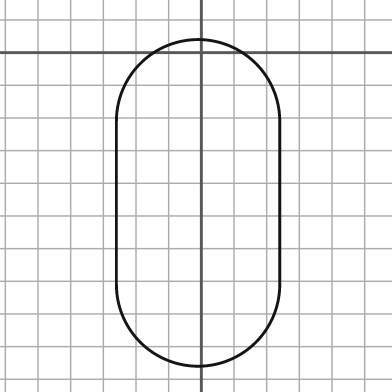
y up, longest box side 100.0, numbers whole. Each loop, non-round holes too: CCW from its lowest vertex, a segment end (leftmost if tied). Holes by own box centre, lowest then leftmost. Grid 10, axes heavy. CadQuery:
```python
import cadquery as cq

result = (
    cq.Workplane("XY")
    .moveTo(-26.0, -71.0)
    .threePointArc((-1.0, -96.0), (24.0, -71.0))
    .lineTo(24.0, -21.0)
    .threePointArc((-1.0, 4.0), (-26.0, -21.0))
    .close()
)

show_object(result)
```